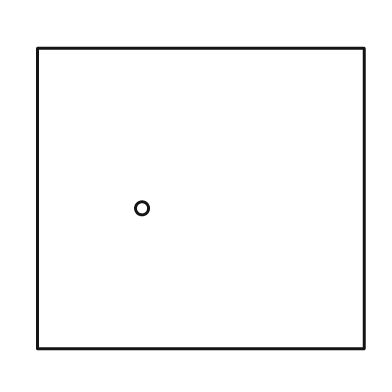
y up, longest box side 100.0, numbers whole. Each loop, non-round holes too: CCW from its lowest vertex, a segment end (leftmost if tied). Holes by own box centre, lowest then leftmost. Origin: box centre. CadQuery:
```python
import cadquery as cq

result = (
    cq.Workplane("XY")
    .moveTo(-50.0, -46.0)
    .lineTo(50.0, -46.0)
    .lineTo(50.0, 46.0)
    .lineTo(-50.0, 46.0)
    .close()
    .moveTo(-18.0, -3.0)
    .circle(2.0)
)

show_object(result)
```